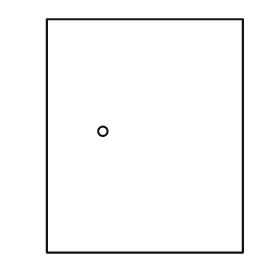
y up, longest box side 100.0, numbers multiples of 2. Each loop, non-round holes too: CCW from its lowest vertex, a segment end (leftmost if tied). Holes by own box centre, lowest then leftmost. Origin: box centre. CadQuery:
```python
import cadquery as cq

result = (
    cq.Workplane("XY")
    .moveTo(-42.0, -50.0)
    .lineTo(42.0, -50.0)
    .lineTo(42.0, 50.0)
    .lineTo(-42.0, 50.0)
    .close()
    .moveTo(-18.0, 2.0)
    .circle(2.0)
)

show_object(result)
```